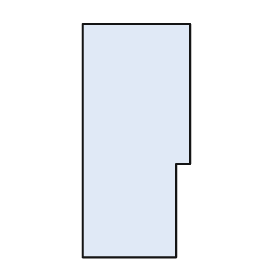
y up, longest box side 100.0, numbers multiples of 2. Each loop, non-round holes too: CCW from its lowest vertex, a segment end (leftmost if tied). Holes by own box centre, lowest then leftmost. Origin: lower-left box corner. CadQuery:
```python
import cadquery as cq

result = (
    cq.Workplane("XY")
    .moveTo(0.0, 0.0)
    .lineTo(40.0, 0.0)
    .lineTo(40.0, 40.0)
    .lineTo(46.0, 40.0)
    .lineTo(46.0, 100.0)
    .lineTo(0.0, 100.0)
    .close()
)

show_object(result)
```